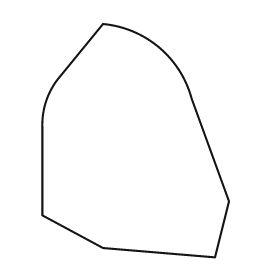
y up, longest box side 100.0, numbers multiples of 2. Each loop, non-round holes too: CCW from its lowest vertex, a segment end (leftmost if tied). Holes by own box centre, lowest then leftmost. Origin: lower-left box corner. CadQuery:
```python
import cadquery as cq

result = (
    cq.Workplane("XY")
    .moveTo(74.0, 0.0)
    .lineTo(80.0, 24.0)
    .lineTo(64.0, 68.0)
    .threePointArc((50.0, 90.0), (26.0, 100.0))
    .lineTo(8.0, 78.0)
    .threePointArc((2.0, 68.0), (0.0, 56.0))
    .lineTo(0.0, 18.0)
    .lineTo(26.0, 4.0)
    .close()
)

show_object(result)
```